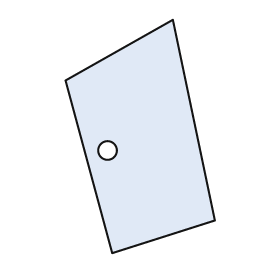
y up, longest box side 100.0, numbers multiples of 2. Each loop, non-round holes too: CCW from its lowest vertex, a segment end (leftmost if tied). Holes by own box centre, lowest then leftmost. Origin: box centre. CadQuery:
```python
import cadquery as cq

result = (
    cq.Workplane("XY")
    .moveTo(-12.0, -50.0)
    .lineTo(32.0, -36.0)
    .lineTo(14.0, 50.0)
    .lineTo(-32.0, 24.0)
    .close()
    .moveTo(-14.0, -6.0)
    .circle(4.0)
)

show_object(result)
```